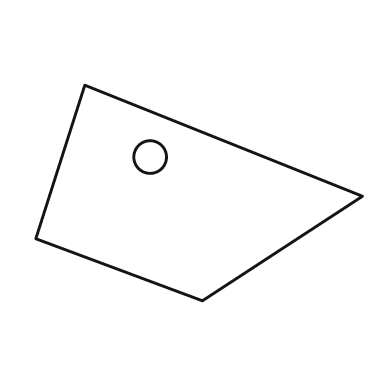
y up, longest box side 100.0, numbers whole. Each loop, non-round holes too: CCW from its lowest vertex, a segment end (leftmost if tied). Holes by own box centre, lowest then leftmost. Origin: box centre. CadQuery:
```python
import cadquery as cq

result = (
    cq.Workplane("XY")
    .moveTo(1.0, -33.0)
    .lineTo(50.0, -1.0)
    .lineTo(-35.0, 33.0)
    .lineTo(-50.0, -14.0)
    .close()
    .moveTo(-15.0, 11.0)
    .circle(5.0)
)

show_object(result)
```